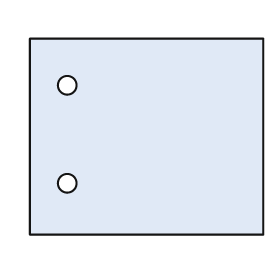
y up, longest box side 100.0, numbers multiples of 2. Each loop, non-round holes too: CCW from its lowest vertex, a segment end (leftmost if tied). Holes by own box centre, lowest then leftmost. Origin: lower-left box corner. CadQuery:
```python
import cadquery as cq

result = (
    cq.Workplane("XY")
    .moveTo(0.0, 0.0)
    .lineTo(100.0, 0.0)
    .lineTo(100.0, 84.0)
    .lineTo(0.0, 84.0)
    .close()
    .moveTo(16.0, 22.0)
    .circle(4.0)
    .moveTo(16.0, 64.0)
    .circle(4.0)
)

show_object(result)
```